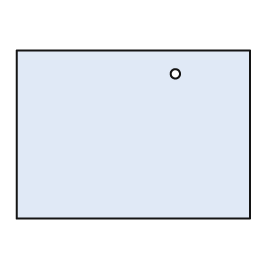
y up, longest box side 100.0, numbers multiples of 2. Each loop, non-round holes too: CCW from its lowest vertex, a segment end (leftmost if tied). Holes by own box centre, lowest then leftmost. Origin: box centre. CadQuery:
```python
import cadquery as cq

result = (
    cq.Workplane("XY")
    .moveTo(-50.0, -36.0)
    .lineTo(50.0, -36.0)
    .lineTo(50.0, 36.0)
    .lineTo(-50.0, 36.0)
    .close()
    .moveTo(18.0, 26.0)
    .circle(2.0)
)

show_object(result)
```